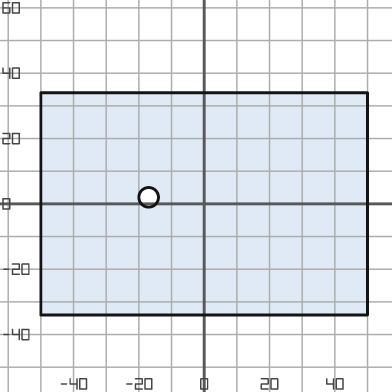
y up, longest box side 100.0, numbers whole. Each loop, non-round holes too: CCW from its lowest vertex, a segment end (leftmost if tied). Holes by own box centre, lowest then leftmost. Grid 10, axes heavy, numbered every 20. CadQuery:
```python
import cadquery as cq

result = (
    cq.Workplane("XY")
    .moveTo(-50.0, -34.0)
    .lineTo(50.0, -34.0)
    .lineTo(50.0, 34.0)
    .lineTo(-50.0, 34.0)
    .close()
    .moveTo(-17.0, 2.0)
    .circle(3.0)
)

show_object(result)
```